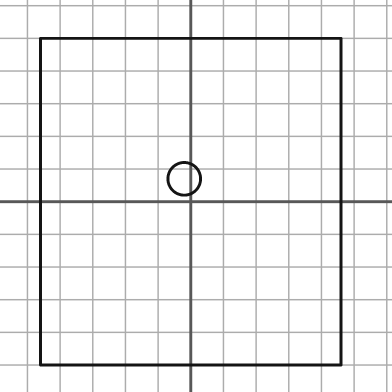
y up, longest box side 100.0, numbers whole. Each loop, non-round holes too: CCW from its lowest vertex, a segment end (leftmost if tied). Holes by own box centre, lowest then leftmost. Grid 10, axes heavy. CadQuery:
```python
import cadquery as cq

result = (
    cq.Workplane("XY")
    .moveTo(-46.0, -50.0)
    .lineTo(46.0, -50.0)
    .lineTo(46.0, 50.0)
    .lineTo(-46.0, 50.0)
    .close()
    .moveTo(-2.0, 7.0)
    .circle(5.0)
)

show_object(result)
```